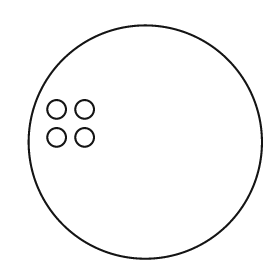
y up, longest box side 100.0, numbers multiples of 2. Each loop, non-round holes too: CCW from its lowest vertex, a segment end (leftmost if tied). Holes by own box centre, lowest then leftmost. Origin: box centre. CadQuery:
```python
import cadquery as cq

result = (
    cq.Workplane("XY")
    .moveTo(0.0, 0.0)
    .circle(50.0)
    .moveTo(-38.0, 2.0)
    .circle(4.0)
    .moveTo(-26.0, 2.0)
    .circle(4.0)
    .moveTo(-38.0, 14.0)
    .circle(4.0)
    .moveTo(-26.0, 14.0)
    .circle(4.0)
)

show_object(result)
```